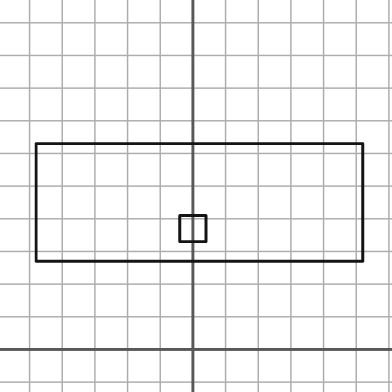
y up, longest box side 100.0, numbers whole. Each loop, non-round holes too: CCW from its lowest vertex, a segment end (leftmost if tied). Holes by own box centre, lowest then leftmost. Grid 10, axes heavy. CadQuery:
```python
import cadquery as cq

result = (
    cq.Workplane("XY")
    .moveTo(-48.0, 27.0)
    .lineTo(52.0, 27.0)
    .lineTo(52.0, 63.0)
    .lineTo(-48.0, 63.0)
    .close()
    .moveTo(-4.0, 33.0)
    .lineTo(4.0, 33.0)
    .lineTo(4.0, 41.0)
    .lineTo(-4.0, 41.0)
    .close()
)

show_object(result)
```